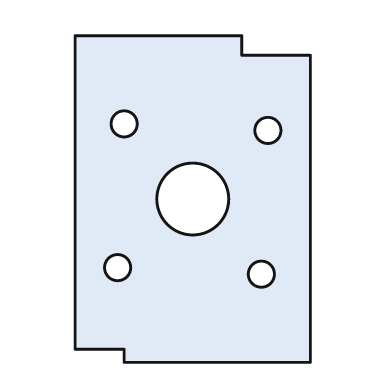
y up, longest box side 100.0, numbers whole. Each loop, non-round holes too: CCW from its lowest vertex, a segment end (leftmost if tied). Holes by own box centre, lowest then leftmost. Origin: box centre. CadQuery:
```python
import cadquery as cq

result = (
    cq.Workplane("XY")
    .moveTo(-21.0, -50.0)
    .lineTo(36.0, -50.0)
    .lineTo(36.0, 44.0)
    .lineTo(15.0, 44.0)
    .lineTo(15.0, 50.0)
    .lineTo(-36.0, 50.0)
    .lineTo(-36.0, -46.0)
    .lineTo(-21.0, -46.0)
    .close()
    .moveTo(21.0, -23.0)
    .circle(4.0)
    .moveTo(-23.0, -21.0)
    .circle(4.0)
    .moveTo(0.0, 0.0)
    .circle(11.0)
    .moveTo(23.0, 21.0)
    .circle(4.0)
    .moveTo(-21.0, 23.0)
    .circle(4.0)
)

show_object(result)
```